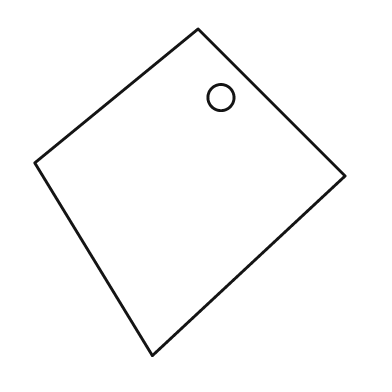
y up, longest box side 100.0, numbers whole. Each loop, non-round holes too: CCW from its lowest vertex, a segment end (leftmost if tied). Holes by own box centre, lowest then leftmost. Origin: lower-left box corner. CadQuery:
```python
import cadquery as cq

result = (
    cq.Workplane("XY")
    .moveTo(36.0, 0.0)
    .lineTo(95.0, 55.0)
    .lineTo(50.0, 100.0)
    .lineTo(0.0, 59.0)
    .close()
    .moveTo(57.0, 79.0)
    .circle(4.0)
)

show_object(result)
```